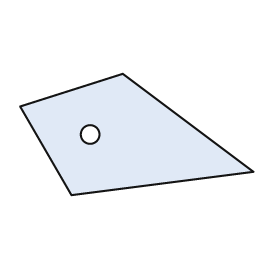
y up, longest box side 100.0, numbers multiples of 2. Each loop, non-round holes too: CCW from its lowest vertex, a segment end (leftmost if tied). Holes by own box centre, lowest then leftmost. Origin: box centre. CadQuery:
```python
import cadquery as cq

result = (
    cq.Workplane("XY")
    .moveTo(-28.0, -26.0)
    .lineTo(50.0, -16.0)
    .lineTo(-6.0, 26.0)
    .lineTo(-50.0, 12.0)
    .close()
    .moveTo(-20.0, 0.0)
    .circle(4.0)
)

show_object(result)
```